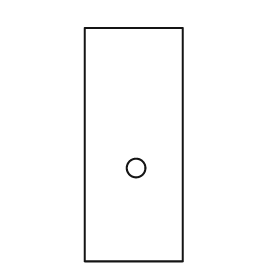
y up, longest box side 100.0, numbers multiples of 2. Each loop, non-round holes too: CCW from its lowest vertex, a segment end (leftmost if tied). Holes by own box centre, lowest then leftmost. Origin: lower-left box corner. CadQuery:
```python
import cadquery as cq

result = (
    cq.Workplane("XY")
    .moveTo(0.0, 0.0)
    .lineTo(42.0, 0.0)
    .lineTo(42.0, 100.0)
    .lineTo(0.0, 100.0)
    .close()
    .moveTo(22.0, 40.0)
    .circle(4.0)
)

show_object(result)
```